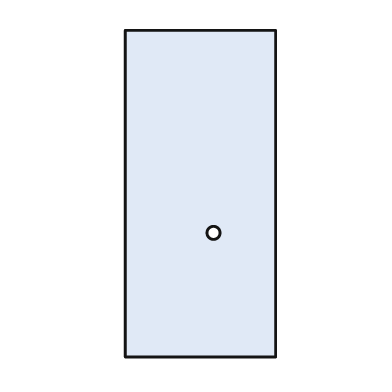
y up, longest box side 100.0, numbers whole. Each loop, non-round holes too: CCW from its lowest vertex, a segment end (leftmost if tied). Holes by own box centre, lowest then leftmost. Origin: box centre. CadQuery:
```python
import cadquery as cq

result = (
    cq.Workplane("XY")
    .moveTo(-23.0, -50.0)
    .lineTo(23.0, -50.0)
    .lineTo(23.0, 50.0)
    .lineTo(-23.0, 50.0)
    .close()
    .moveTo(4.0, -12.0)
    .circle(2.0)
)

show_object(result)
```